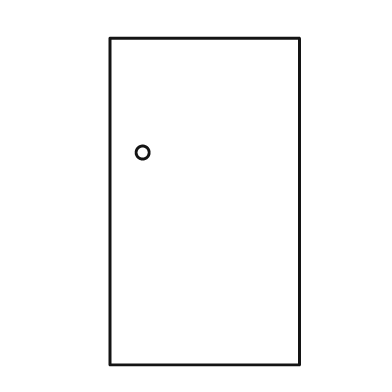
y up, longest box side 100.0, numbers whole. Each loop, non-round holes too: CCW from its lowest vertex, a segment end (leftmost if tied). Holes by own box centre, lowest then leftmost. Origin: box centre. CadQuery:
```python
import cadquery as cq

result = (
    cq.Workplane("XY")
    .moveTo(-29.0, -50.0)
    .lineTo(29.0, -50.0)
    .lineTo(29.0, 50.0)
    .lineTo(-29.0, 50.0)
    .close()
    .moveTo(-19.0, 15.0)
    .circle(2.0)
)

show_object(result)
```